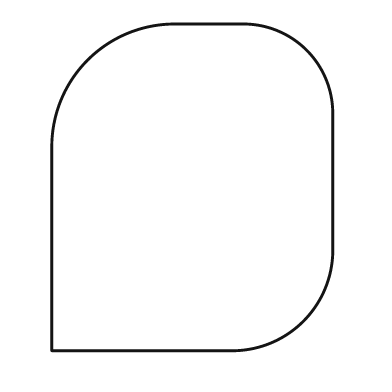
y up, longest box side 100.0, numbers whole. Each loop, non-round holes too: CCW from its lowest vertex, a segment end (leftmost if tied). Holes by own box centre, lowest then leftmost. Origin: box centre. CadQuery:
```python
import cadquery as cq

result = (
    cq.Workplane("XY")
    .moveTo(-43.0, -50.0)
    .lineTo(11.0, -50.0)
    .threePointArc((34.0, -41.0), (43.0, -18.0))
    .lineTo(43.0, 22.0)
    .threePointArc((35.0, 42.0), (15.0, 50.0))
    .lineTo(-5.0, 50.0)
    .threePointArc((-32.0, 39.0), (-43.0, 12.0))
    .close()
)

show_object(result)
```